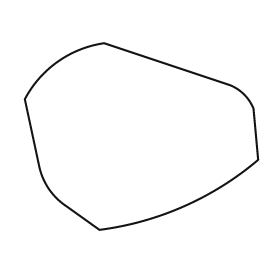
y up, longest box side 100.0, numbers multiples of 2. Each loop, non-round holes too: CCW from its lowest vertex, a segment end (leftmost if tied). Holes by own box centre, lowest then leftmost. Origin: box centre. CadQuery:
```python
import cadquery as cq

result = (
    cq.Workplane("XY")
    .moveTo(-18.0, -40.0)
    .threePointArc((18.0, -30.0), (50.0, -10.0))
    .lineTo(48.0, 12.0)
    .threePointArc((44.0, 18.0), (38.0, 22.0))
    .lineTo(-16.0, 40.0)
    .threePointArc((-36.0, 32.0), (-50.0, 16.0))
    .lineTo(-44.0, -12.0)
    .threePointArc((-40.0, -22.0), (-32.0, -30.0))
    .close()
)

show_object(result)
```